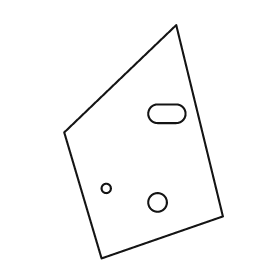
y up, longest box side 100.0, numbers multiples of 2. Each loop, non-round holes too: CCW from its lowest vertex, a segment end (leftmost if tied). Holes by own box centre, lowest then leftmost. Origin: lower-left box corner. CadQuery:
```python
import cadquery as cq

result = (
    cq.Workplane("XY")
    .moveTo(16.0, 0.0)
    .lineTo(68.0, 18.0)
    .lineTo(48.0, 100.0)
    .lineTo(0.0, 54.0)
    .close()
    .moveTo(40.0, 24.0)
    .circle(4.0)
    .moveTo(18.0, 30.0)
    .circle(2.0)
    .moveTo(40.0, 58.0)
    .lineTo(48.0, 58.0)
    .threePointArc((52.0, 62.0), (48.0, 66.0))
    .lineTo(40.0, 66.0)
    .threePointArc((36.0, 62.0), (40.0, 58.0))
    .close()
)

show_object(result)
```